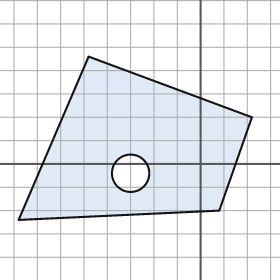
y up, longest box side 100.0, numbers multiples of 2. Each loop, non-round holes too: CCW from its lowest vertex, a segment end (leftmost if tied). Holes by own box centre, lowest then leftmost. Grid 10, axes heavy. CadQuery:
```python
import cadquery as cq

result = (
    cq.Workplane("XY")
    .moveTo(-78.0, -24.0)
    .lineTo(8.0, -20.0)
    .lineTo(22.0, 20.0)
    .lineTo(-48.0, 46.0)
    .close()
    .moveTo(-30.0, -4.0)
    .circle(8.0)
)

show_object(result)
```